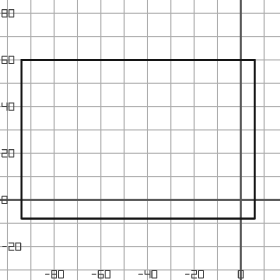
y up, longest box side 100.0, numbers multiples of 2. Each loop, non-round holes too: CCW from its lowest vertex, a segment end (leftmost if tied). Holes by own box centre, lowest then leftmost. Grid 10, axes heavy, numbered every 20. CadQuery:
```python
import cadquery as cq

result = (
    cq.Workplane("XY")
    .moveTo(-94.0, -8.0)
    .lineTo(6.0, -8.0)
    .lineTo(6.0, 60.0)
    .lineTo(-94.0, 60.0)
    .close()
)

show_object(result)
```